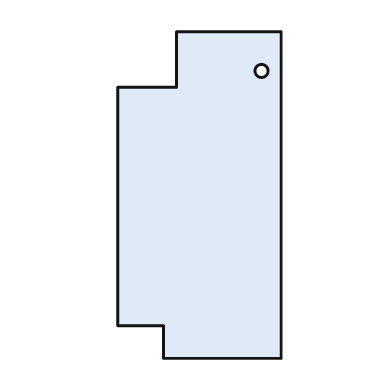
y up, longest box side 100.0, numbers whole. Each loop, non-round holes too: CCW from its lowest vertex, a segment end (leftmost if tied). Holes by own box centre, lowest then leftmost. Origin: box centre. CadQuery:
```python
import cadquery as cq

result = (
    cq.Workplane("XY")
    .moveTo(-11.0, -50.0)
    .lineTo(25.0, -50.0)
    .lineTo(25.0, 50.0)
    .lineTo(-7.0, 50.0)
    .lineTo(-7.0, 33.0)
    .lineTo(-25.0, 33.0)
    .lineTo(-25.0, -40.0)
    .lineTo(-11.0, -40.0)
    .close()
    .moveTo(19.0, 38.0)
    .circle(2.0)
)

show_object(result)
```